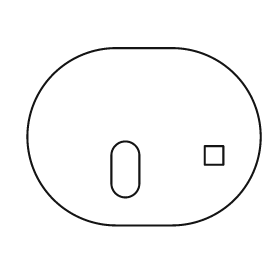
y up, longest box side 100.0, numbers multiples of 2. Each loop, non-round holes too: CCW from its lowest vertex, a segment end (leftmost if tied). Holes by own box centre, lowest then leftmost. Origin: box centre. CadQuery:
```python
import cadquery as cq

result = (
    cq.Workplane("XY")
    .moveTo(-12.0, -38.0)
    .lineTo(12.0, -38.0)
    .threePointArc((50.0, 0.0), (12.0, 38.0))
    .lineTo(-12.0, 38.0)
    .threePointArc((-50.0, 0.0), (-12.0, -38.0))
    .close()
    .moveTo(-14.0, -20.0)
    .threePointArc((-8.0, -26.0), (-2.0, -20.0))
    .lineTo(-2.0, -8.0)
    .threePointArc((-8.0, -2.0), (-14.0, -8.0))
    .close()
    .moveTo(26.0, -12.0)
    .lineTo(34.0, -12.0)
    .lineTo(34.0, -4.0)
    .lineTo(26.0, -4.0)
    .close()
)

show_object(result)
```